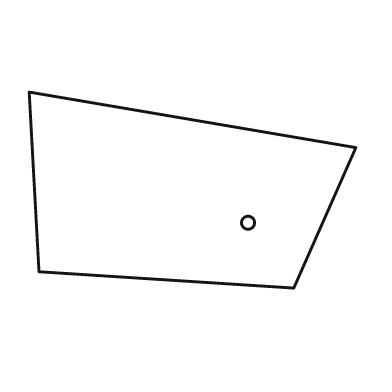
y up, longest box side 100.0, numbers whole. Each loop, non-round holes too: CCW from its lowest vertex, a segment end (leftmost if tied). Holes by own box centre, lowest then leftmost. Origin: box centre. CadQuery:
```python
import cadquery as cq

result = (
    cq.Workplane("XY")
    .moveTo(31.0, -30.0)
    .lineTo(50.0, 13.0)
    .lineTo(-50.0, 30.0)
    .lineTo(-47.0, -25.0)
    .close()
    .moveTo(17.0, -10.0)
    .circle(2.0)
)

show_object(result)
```